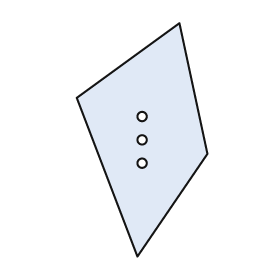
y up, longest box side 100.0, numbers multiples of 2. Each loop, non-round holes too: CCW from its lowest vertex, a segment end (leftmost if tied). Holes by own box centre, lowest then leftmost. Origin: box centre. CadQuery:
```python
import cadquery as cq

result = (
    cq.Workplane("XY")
    .moveTo(-2.0, -50.0)
    .lineTo(28.0, -6.0)
    .lineTo(16.0, 50.0)
    .lineTo(-28.0, 18.0)
    .close()
    .moveTo(0.0, -10.0)
    .circle(2.0)
    .moveTo(0.0, 0.0)
    .circle(2.0)
    .moveTo(0.0, 10.0)
    .circle(2.0)
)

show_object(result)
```